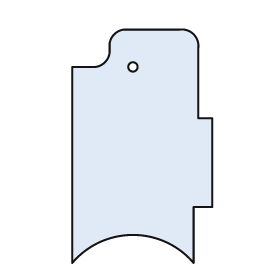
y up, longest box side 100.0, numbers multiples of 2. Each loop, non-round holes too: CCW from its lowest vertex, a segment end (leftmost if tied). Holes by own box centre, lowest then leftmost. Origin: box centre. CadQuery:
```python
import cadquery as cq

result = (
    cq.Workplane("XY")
    .moveTo(-30.0, -50.0)
    .threePointArc((-4.0, -38.0), (22.0, -50.0))
    .lineTo(22.0, -26.0)
    .lineTo(30.0, -26.0)
    .lineTo(30.0, 12.0)
    .lineTo(24.0, 12.0)
    .lineTo(24.0, 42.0)
    .threePointArc((22.0, 48.0), (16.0, 50.0))
    .lineTo(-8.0, 50.0)
    .threePointArc((-12.0, 48.0), (-14.0, 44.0))
    .lineTo(-14.0, 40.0)
    .threePointArc((-16.0, 36.0), (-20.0, 34.0))
    .lineTo(-30.0, 34.0)
    .close()
    .moveTo(-4.0, 34.0)
    .circle(2.0)
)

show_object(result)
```